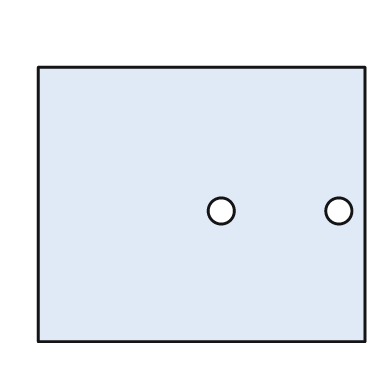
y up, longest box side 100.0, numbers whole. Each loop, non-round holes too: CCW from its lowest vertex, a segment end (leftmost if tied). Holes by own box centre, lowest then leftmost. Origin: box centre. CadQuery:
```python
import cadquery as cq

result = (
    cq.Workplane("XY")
    .moveTo(-50.0, -42.0)
    .lineTo(50.0, -42.0)
    .lineTo(50.0, 42.0)
    .lineTo(-50.0, 42.0)
    .close()
    .moveTo(6.0, -2.0)
    .circle(4.0)
    .moveTo(42.0, -2.0)
    .circle(4.0)
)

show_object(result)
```